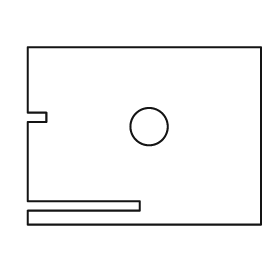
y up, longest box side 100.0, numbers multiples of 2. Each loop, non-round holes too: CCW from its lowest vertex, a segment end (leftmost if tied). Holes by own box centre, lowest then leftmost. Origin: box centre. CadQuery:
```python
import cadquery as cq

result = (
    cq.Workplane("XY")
    .moveTo(-50.0, -38.0)
    .lineTo(50.0, -38.0)
    .lineTo(50.0, 38.0)
    .lineTo(-50.0, 38.0)
    .lineTo(-50.0, 10.0)
    .lineTo(-42.0, 10.0)
    .lineTo(-42.0, 6.0)
    .lineTo(-50.0, 6.0)
    .lineTo(-50.0, -28.0)
    .lineTo(-2.0, -28.0)
    .lineTo(-2.0, -32.0)
    .lineTo(-50.0, -32.0)
    .close()
    .moveTo(2.0, 4.0)
    .circle(8.0)
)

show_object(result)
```